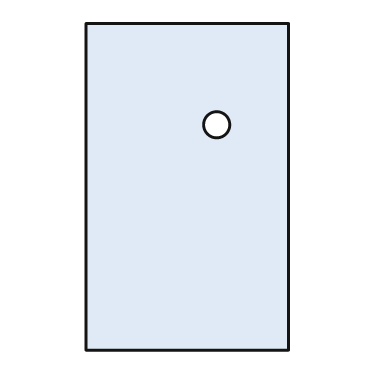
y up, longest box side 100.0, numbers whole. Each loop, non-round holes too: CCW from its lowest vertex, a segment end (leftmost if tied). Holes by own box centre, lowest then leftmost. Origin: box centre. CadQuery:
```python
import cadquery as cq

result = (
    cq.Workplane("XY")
    .moveTo(-31.0, -50.0)
    .lineTo(31.0, -50.0)
    .lineTo(31.0, 50.0)
    .lineTo(-31.0, 50.0)
    .close()
    .moveTo(9.0, 19.0)
    .circle(4.0)
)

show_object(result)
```